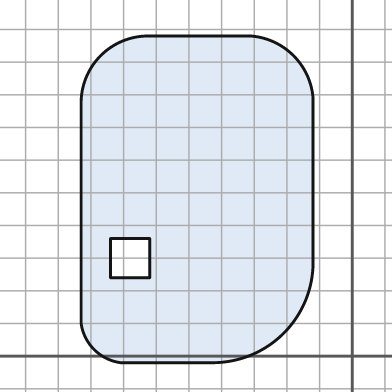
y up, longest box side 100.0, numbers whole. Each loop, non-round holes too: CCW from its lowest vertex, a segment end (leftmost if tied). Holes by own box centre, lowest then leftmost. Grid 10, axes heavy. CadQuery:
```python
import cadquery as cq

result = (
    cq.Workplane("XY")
    .moveTo(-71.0, -2.0)
    .lineTo(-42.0, -2.0)
    .threePointArc((-21.0, 7.0), (-12.0, 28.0))
    .lineTo(-12.0, 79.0)
    .threePointArc((-18.0, 92.0), (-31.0, 98.0))
    .lineTo(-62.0, 98.0)
    .threePointArc((-77.0, 92.0), (-83.0, 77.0))
    .lineTo(-83.0, 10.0)
    .threePointArc((-79.0, 2.0), (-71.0, -2.0))
    .close()
    .moveTo(-74.0, 24.0)
    .lineTo(-62.0, 24.0)
    .lineTo(-62.0, 36.0)
    .lineTo(-74.0, 36.0)
    .close()
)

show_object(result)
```